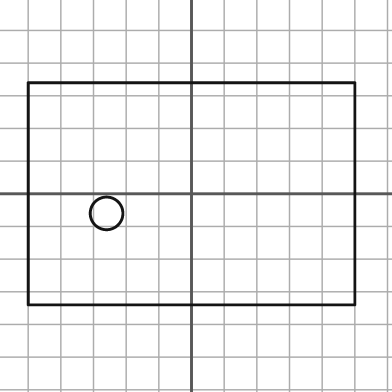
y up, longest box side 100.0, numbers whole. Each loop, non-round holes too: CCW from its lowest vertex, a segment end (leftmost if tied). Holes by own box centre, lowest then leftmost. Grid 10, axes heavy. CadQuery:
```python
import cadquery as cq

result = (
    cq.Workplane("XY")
    .moveTo(-50.0, -34.0)
    .lineTo(50.0, -34.0)
    .lineTo(50.0, 34.0)
    .lineTo(-50.0, 34.0)
    .close()
    .moveTo(-26.0, -6.0)
    .circle(5.0)
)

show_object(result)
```